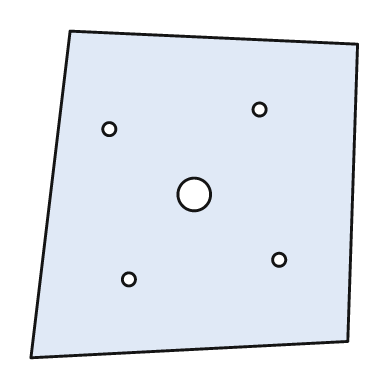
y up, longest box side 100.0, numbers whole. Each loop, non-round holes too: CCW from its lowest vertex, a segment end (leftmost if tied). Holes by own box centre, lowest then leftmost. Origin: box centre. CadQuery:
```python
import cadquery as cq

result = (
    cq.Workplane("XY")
    .moveTo(-50.0, -50.0)
    .lineTo(47.0, -45.0)
    .lineTo(50.0, 46.0)
    .lineTo(-38.0, 50.0)
    .close()
    .moveTo(-20.0, -26.0)
    .circle(2.0)
    .moveTo(26.0, -20.0)
    .circle(2.0)
    .moveTo(0.0, 0.0)
    .circle(5.0)
    .moveTo(-26.0, 20.0)
    .circle(2.0)
    .moveTo(20.0, 26.0)
    .circle(2.0)
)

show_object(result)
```